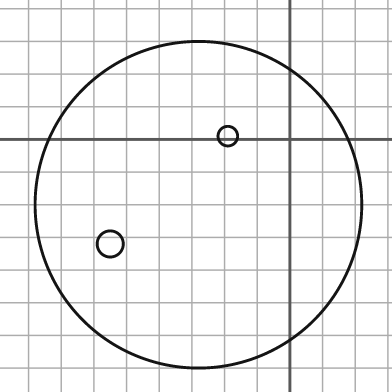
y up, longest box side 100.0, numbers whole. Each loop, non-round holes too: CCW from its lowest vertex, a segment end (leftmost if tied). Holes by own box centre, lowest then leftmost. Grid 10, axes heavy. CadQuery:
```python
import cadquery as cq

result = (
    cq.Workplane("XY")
    .moveTo(-28.0, -20.0)
    .circle(50.0)
    .moveTo(-55.0, -32.0)
    .circle(4.0)
    .moveTo(-19.0, 1.0)
    .circle(3.0)
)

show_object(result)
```